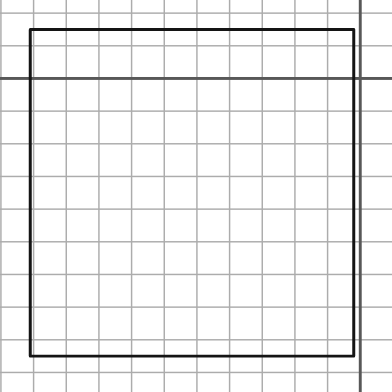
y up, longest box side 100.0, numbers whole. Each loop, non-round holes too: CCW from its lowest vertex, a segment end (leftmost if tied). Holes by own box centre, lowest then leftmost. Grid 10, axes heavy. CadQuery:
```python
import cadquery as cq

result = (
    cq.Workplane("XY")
    .moveTo(-101.0, -85.0)
    .lineTo(-2.0, -85.0)
    .lineTo(-2.0, 15.0)
    .lineTo(-101.0, 15.0)
    .close()
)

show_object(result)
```